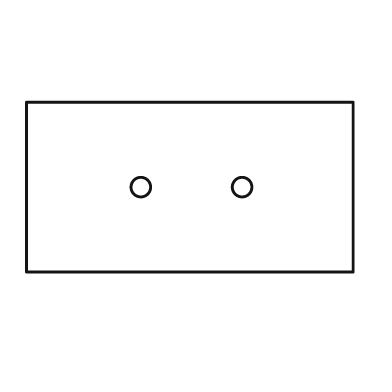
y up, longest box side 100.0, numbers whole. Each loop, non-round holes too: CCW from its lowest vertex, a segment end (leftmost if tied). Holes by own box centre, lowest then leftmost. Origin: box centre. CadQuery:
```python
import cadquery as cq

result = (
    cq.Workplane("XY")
    .moveTo(-50.0, -26.0)
    .lineTo(50.0, -26.0)
    .lineTo(50.0, 26.0)
    .lineTo(-50.0, 26.0)
    .close()
    .moveTo(-15.0, 0.0)
    .circle(3.0)
    .moveTo(16.0, 0.0)
    .circle(3.0)
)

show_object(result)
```